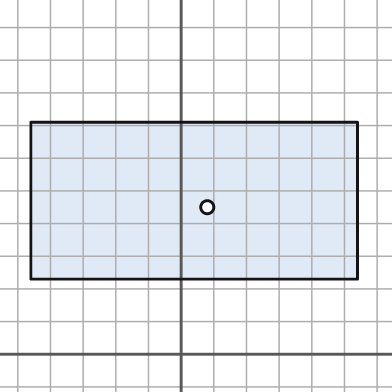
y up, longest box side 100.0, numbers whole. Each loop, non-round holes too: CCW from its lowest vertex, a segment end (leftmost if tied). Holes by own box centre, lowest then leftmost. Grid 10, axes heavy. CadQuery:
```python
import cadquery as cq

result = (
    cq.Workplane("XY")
    .moveTo(-46.0, 23.0)
    .lineTo(54.0, 23.0)
    .lineTo(54.0, 71.0)
    .lineTo(-46.0, 71.0)
    .close()
    .moveTo(8.0, 45.0)
    .circle(2.0)
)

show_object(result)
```